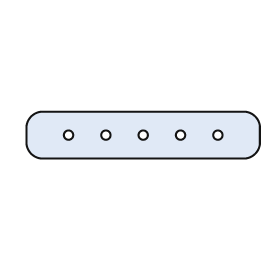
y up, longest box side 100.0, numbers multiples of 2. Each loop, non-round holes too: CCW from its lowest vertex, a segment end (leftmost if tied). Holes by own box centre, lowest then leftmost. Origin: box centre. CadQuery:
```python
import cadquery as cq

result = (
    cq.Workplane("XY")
    .moveTo(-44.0, -10.0)
    .lineTo(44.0, -10.0)
    .threePointArc((48.0, -8.0), (50.0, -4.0))
    .lineTo(50.0, 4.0)
    .threePointArc((48.0, 8.0), (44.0, 10.0))
    .lineTo(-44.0, 10.0)
    .threePointArc((-48.0, 8.0), (-50.0, 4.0))
    .lineTo(-50.0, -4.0)
    .threePointArc((-48.0, -8.0), (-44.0, -10.0))
    .close()
    .moveTo(-32.0, 0.0)
    .circle(2.0)
    .moveTo(-16.0, 0.0)
    .circle(2.0)
    .moveTo(0.0, 0.0)
    .circle(2.0)
    .moveTo(16.0, 0.0)
    .circle(2.0)
    .moveTo(32.0, 0.0)
    .circle(2.0)
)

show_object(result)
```